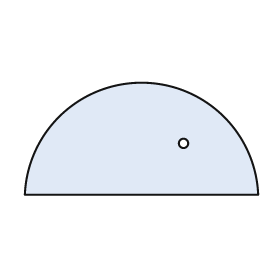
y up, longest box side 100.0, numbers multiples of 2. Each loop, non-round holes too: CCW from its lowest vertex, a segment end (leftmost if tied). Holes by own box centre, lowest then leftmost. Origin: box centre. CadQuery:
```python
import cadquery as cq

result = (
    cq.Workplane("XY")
    .moveTo(-50.0, -24.0)
    .lineTo(50.0, -24.0)
    .threePointArc((0.0, 24.0), (-50.0, -24.0))
    .close()
    .moveTo(18.0, -2.0)
    .circle(2.0)
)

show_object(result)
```